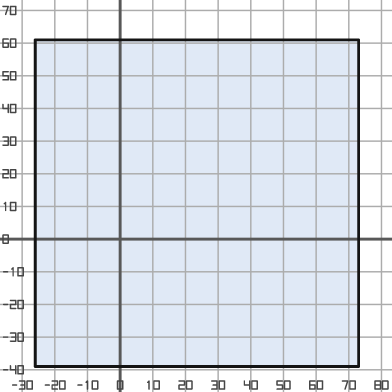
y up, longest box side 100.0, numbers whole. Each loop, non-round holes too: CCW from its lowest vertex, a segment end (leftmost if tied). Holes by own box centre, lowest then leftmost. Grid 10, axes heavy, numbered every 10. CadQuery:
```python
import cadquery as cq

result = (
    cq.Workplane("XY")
    .moveTo(-26.0, -39.0)
    .lineTo(73.0, -39.0)
    .lineTo(73.0, 61.0)
    .lineTo(-26.0, 61.0)
    .close()
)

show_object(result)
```